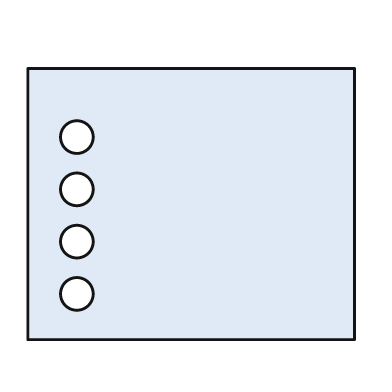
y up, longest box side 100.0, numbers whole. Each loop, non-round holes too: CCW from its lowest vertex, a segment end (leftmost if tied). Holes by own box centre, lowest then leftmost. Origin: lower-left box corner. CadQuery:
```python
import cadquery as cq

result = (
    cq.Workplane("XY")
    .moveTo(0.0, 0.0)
    .lineTo(100.0, 0.0)
    .lineTo(100.0, 83.0)
    .lineTo(0.0, 83.0)
    .close()
    .moveTo(15.0, 14.0)
    .circle(5.0)
    .moveTo(15.0, 30.0)
    .circle(5.0)
    .moveTo(15.0, 46.0)
    .circle(5.0)
    .moveTo(15.0, 62.0)
    .circle(5.0)
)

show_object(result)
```